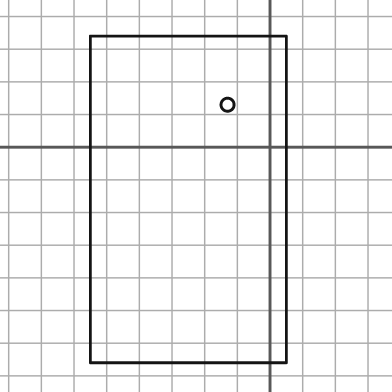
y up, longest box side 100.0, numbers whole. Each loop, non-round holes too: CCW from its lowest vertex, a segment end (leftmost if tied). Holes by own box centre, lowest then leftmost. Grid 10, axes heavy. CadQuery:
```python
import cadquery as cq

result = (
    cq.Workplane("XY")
    .moveTo(-55.0, -66.0)
    .lineTo(5.0, -66.0)
    .lineTo(5.0, 34.0)
    .lineTo(-55.0, 34.0)
    .close()
    .moveTo(-13.0, 13.0)
    .circle(2.0)
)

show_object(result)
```